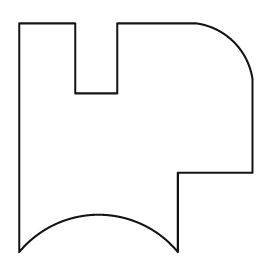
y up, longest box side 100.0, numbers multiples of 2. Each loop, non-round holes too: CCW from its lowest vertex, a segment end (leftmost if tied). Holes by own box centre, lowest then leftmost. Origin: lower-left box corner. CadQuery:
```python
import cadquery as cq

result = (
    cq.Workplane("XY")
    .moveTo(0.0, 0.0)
    .threePointArc((34.0, 16.0), (68.0, 0.0))
    .lineTo(68.0, 34.0)
    .lineTo(100.0, 34.0)
    .lineTo(100.0, 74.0)
    .threePointArc((92.0, 90.0), (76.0, 98.0))
    .lineTo(42.0, 98.0)
    .lineTo(42.0, 68.0)
    .lineTo(24.0, 68.0)
    .lineTo(24.0, 98.0)
    .lineTo(0.0, 98.0)
    .close()
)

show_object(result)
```